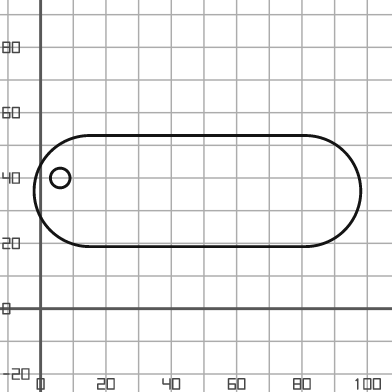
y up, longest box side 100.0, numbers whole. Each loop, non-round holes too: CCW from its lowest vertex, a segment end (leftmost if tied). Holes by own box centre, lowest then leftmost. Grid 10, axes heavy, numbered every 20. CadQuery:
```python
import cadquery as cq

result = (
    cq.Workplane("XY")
    .moveTo(15.0, 19.0)
    .lineTo(81.0, 19.0)
    .threePointArc((98.0, 36.0), (81.0, 53.0))
    .lineTo(15.0, 53.0)
    .threePointArc((-2.0, 36.0), (15.0, 19.0))
    .close()
    .moveTo(6.0, 40.0)
    .circle(3.0)
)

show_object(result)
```